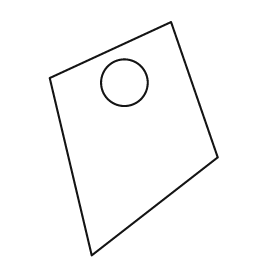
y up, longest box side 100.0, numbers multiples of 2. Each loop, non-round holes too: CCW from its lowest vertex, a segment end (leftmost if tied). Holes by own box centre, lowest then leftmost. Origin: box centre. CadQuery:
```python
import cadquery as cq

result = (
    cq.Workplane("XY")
    .moveTo(-18.0, -50.0)
    .lineTo(36.0, -8.0)
    .lineTo(16.0, 50.0)
    .lineTo(-36.0, 26.0)
    .close()
    .moveTo(-4.0, 24.0)
    .circle(10.0)
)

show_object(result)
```